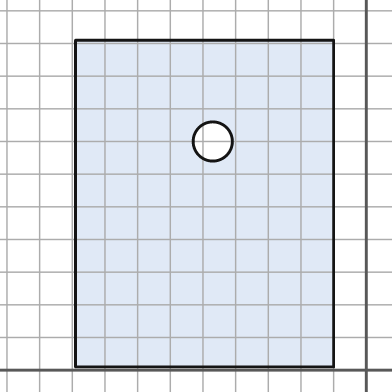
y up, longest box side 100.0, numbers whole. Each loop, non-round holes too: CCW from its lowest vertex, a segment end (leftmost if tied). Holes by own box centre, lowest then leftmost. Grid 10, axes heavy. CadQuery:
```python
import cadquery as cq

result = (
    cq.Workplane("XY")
    .moveTo(-89.0, 1.0)
    .lineTo(-10.0, 1.0)
    .lineTo(-10.0, 101.0)
    .lineTo(-89.0, 101.0)
    .close()
    .moveTo(-47.0, 70.0)
    .circle(6.0)
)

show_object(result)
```